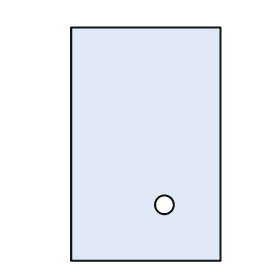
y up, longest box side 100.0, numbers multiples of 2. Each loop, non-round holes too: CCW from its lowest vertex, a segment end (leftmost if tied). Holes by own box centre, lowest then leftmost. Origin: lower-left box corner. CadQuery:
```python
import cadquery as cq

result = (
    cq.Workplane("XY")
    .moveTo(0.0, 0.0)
    .lineTo(64.0, 0.0)
    .lineTo(64.0, 100.0)
    .lineTo(0.0, 100.0)
    .close()
    .moveTo(40.0, 24.0)
    .circle(4.0)
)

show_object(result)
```